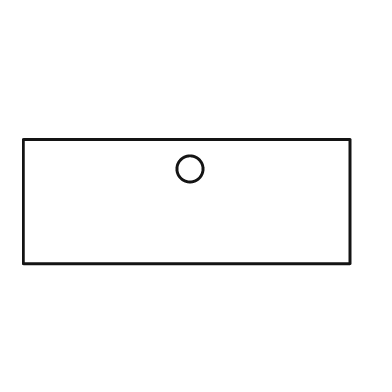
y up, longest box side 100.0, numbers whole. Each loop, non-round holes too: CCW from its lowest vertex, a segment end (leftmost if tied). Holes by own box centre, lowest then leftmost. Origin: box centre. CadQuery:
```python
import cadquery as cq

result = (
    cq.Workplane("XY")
    .moveTo(-50.0, -19.0)
    .lineTo(50.0, -19.0)
    .lineTo(50.0, 19.0)
    .lineTo(-50.0, 19.0)
    .close()
    .moveTo(1.0, 10.0)
    .circle(4.0)
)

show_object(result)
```